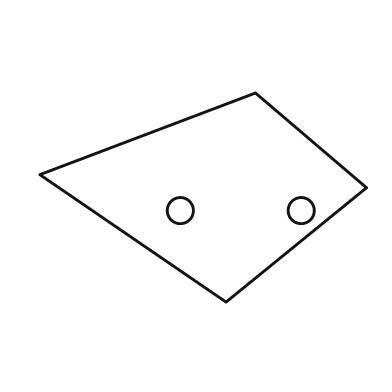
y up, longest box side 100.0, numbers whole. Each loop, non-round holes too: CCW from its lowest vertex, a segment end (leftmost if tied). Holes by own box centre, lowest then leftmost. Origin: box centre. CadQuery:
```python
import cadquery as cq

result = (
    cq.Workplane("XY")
    .moveTo(7.0, -32.0)
    .lineTo(50.0, 3.0)
    .lineTo(16.0, 32.0)
    .lineTo(-50.0, 7.0)
    .close()
    .moveTo(-7.0, -4.0)
    .circle(4.0)
    .moveTo(30.0, -4.0)
    .circle(4.0)
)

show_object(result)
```